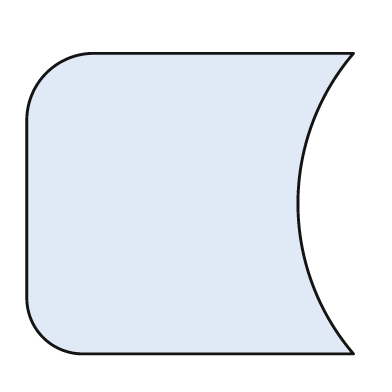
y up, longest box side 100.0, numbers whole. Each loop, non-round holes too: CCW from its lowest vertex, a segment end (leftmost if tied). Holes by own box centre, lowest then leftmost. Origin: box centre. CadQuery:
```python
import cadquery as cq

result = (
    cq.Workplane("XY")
    .moveTo(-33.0, -46.0)
    .lineTo(50.0, -46.0)
    .threePointArc((33.0, 0.0), (50.0, 46.0))
    .lineTo(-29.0, 46.0)
    .threePointArc((-44.0, 40.0), (-50.0, 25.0))
    .lineTo(-50.0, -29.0)
    .threePointArc((-45.0, -41.0), (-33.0, -46.0))
    .close()
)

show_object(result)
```